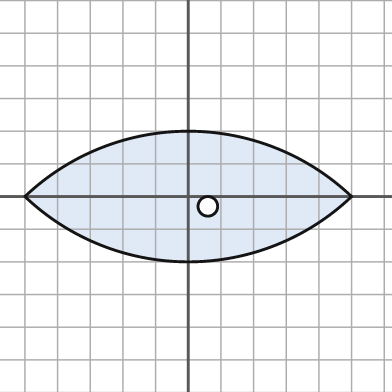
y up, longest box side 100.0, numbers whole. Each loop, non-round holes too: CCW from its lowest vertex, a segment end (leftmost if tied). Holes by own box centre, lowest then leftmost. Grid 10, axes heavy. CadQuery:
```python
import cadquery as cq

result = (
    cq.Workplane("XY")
    .moveTo(-50.0, 0.0)
    .threePointArc((0.0, -20.0), (50.0, 0.0))
    .threePointArc((0.0, 20.0), (-50.0, 0.0))
    .close()
    .moveTo(6.0, -3.0)
    .circle(3.0)
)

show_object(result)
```